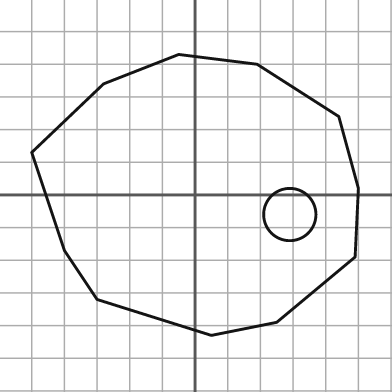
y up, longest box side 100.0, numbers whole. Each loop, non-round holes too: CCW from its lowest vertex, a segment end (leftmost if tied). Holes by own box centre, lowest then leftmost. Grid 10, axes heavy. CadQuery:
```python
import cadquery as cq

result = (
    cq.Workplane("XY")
    .moveTo(5.0, -43.0)
    .lineTo(25.0, -39.0)
    .lineTo(49.0, -19.0)
    .lineTo(50.0, 2.0)
    .lineTo(44.0, 24.0)
    .lineTo(19.0, 40.0)
    .lineTo(-5.0, 43.0)
    .lineTo(-28.0, 34.0)
    .lineTo(-50.0, 13.0)
    .lineTo(-40.0, -17.0)
    .lineTo(-30.0, -32.0)
    .close()
    .moveTo(29.0, -6.0)
    .circle(8.0)
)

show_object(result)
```